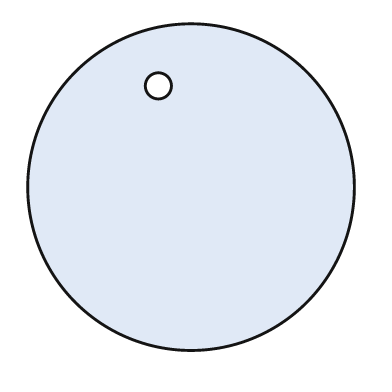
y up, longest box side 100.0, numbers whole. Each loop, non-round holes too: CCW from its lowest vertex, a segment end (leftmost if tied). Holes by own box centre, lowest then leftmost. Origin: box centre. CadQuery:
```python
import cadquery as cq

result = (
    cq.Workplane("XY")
    .moveTo(0.0, 0.0)
    .circle(50.0)
    .moveTo(-10.0, 31.0)
    .circle(4.0)
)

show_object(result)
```